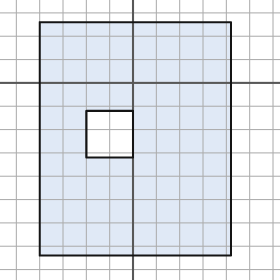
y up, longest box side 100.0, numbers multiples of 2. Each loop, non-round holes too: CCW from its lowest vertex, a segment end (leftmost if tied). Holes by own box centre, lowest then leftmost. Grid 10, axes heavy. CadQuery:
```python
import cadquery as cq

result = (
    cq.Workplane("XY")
    .moveTo(-40.0, -74.0)
    .lineTo(42.0, -74.0)
    .lineTo(42.0, 26.0)
    .lineTo(-40.0, 26.0)
    .close()
    .moveTo(-20.0, -32.0)
    .lineTo(0.0, -32.0)
    .lineTo(0.0, -12.0)
    .lineTo(-20.0, -12.0)
    .close()
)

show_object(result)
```